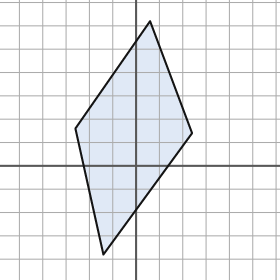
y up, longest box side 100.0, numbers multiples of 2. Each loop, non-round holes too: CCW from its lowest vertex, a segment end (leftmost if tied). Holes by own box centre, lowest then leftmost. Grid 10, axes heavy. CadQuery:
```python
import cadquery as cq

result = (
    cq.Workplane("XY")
    .moveTo(-14.0, -38.0)
    .lineTo(24.0, 14.0)
    .lineTo(6.0, 62.0)
    .lineTo(-26.0, 16.0)
    .close()
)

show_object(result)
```